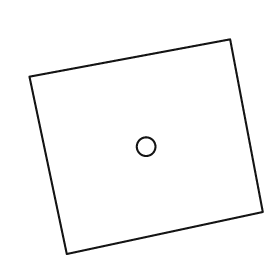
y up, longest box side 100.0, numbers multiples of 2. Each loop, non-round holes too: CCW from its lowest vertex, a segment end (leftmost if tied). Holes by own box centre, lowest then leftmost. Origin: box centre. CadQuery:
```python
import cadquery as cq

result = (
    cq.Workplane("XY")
    .moveTo(-34.0, -46.0)
    .lineTo(50.0, -28.0)
    .lineTo(36.0, 46.0)
    .lineTo(-50.0, 30.0)
    .close()
    .moveTo(0.0, 0.0)
    .circle(4.0)
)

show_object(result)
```